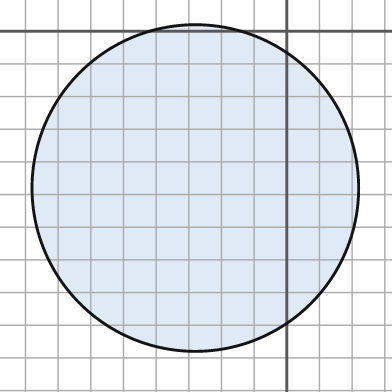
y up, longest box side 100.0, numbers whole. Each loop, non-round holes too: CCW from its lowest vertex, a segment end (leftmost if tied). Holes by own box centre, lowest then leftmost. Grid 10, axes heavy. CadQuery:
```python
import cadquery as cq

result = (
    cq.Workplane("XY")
    .moveTo(-28.0, -48.0)
    .circle(50.0)
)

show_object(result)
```